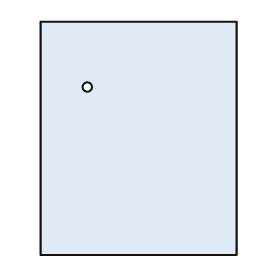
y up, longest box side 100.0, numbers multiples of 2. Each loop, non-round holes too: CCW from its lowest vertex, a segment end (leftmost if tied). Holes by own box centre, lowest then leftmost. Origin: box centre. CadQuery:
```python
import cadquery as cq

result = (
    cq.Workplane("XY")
    .moveTo(-42.0, -50.0)
    .lineTo(42.0, -50.0)
    .lineTo(42.0, 50.0)
    .lineTo(-42.0, 50.0)
    .close()
    .moveTo(-22.0, 22.0)
    .circle(2.0)
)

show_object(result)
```